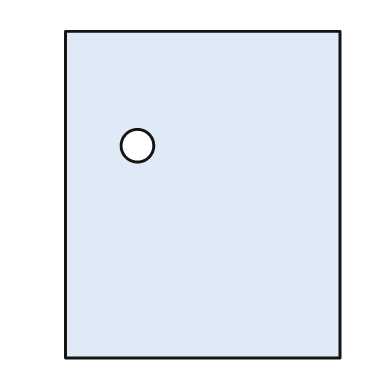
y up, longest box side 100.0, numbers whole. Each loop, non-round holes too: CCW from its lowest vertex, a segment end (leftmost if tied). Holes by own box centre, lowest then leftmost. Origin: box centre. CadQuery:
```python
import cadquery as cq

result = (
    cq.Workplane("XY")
    .moveTo(-42.0, -50.0)
    .lineTo(42.0, -50.0)
    .lineTo(42.0, 50.0)
    .lineTo(-42.0, 50.0)
    .close()
    .moveTo(-20.0, 15.0)
    .circle(5.0)
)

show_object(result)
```